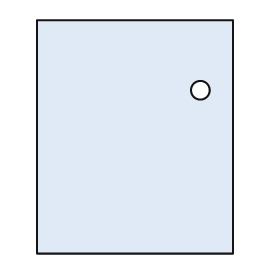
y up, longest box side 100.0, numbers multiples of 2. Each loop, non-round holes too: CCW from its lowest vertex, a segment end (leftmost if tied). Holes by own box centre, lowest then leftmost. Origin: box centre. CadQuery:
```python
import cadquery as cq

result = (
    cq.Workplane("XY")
    .moveTo(-42.0, -50.0)
    .lineTo(42.0, -50.0)
    .lineTo(42.0, 50.0)
    .lineTo(-42.0, 50.0)
    .close()
    .moveTo(28.0, 20.0)
    .circle(4.0)
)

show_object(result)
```